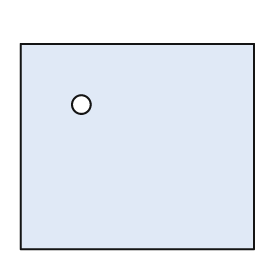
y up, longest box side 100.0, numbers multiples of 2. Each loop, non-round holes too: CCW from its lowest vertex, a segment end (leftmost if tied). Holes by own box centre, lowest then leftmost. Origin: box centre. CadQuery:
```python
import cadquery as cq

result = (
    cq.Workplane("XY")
    .moveTo(-50.0, -44.0)
    .lineTo(50.0, -44.0)
    .lineTo(50.0, 44.0)
    .lineTo(-50.0, 44.0)
    .close()
    .moveTo(-24.0, 18.0)
    .circle(4.0)
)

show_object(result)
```